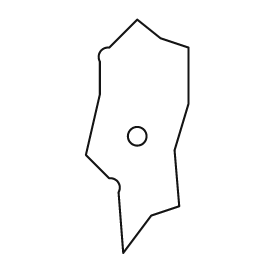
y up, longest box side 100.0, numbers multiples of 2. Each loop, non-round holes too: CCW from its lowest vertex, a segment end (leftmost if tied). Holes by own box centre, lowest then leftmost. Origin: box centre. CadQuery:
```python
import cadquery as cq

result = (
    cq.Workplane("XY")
    .moveTo(-6.0, -50.0)
    .lineTo(6.0, -34.0)
    .lineTo(18.0, -30.0)
    .lineTo(16.0, -6.0)
    .lineTo(22.0, 14.0)
    .lineTo(22.0, 38.0)
    .lineTo(10.0, 42.0)
    .lineTo(0.0, 50.0)
    .lineTo(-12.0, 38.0)
    .threePointArc((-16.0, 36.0), (-16.0, 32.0))
    .lineTo(-16.0, 18.0)
    .lineTo(-22.0, -8.0)
    .lineTo(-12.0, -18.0)
    .threePointArc((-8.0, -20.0), (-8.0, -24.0))
    .close()
    .moveTo(0.0, 0.0)
    .circle(4.0)
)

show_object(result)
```